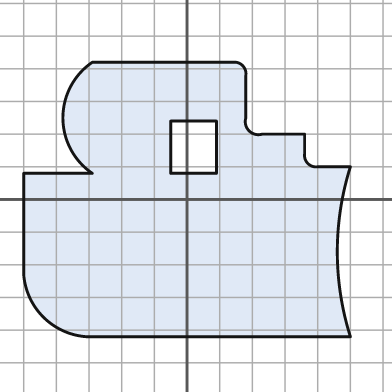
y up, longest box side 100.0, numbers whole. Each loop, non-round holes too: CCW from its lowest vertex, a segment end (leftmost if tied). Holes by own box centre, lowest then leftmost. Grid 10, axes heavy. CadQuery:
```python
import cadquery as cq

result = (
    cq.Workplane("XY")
    .moveTo(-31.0, -42.0)
    .lineTo(50.0, -42.0)
    .threePointArc((46.0, -16.0), (50.0, 10.0))
    .lineTo(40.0, 10.0)
    .threePointArc((37.0, 11.0), (36.0, 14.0))
    .lineTo(36.0, 20.0)
    .lineTo(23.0, 20.0)
    .threePointArc((19.0, 21.0), (18.0, 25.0))
    .lineTo(18.0, 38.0)
    .threePointArc((17.0, 41.0), (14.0, 42.0))
    .lineTo(-29.0, 42.0)
    .threePointArc((-38.0, 25.0), (-29.0, 8.0))
    .lineTo(-50.0, 8.0)
    .lineTo(-50.0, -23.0)
    .threePointArc((-44.0, -36.0), (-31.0, -42.0))
    .close()
    .moveTo(-5.0, 8.0)
    .lineTo(9.0, 8.0)
    .lineTo(9.0, 24.0)
    .lineTo(-5.0, 24.0)
    .close()
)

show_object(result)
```